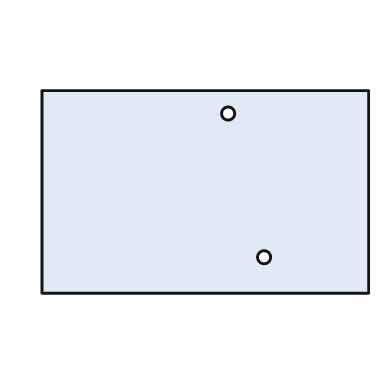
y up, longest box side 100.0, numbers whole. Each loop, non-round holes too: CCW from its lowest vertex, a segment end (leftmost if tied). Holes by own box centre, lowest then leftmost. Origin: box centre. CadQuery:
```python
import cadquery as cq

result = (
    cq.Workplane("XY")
    .moveTo(-50.0, -31.0)
    .lineTo(50.0, -31.0)
    .lineTo(50.0, 31.0)
    .lineTo(-50.0, 31.0)
    .close()
    .moveTo(18.0, -20.0)
    .circle(2.0)
    .moveTo(7.0, 24.0)
    .circle(2.0)
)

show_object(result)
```